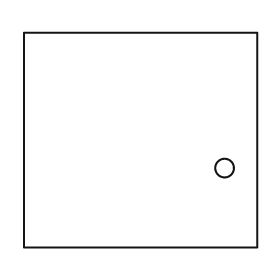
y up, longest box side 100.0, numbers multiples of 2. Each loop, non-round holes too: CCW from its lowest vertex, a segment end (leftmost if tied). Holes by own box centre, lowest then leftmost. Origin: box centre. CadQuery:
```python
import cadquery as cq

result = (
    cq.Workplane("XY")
    .moveTo(-50.0, -46.0)
    .lineTo(50.0, -46.0)
    .lineTo(50.0, 46.0)
    .lineTo(-50.0, 46.0)
    .close()
    .moveTo(36.0, -12.0)
    .circle(4.0)
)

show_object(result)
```